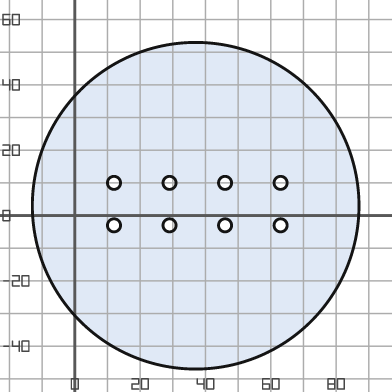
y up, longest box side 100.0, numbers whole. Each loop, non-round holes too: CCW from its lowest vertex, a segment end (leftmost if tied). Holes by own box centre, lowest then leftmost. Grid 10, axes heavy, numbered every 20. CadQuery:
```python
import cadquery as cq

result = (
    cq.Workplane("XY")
    .moveTo(37.0, 3.0)
    .circle(50.0)
    .moveTo(12.0, -3.0)
    .circle(2.0)
    .moveTo(29.0, -3.0)
    .circle(2.0)
    .moveTo(46.0, -3.0)
    .circle(2.0)
    .moveTo(63.0, -3.0)
    .circle(2.0)
    .moveTo(12.0, 10.0)
    .circle(2.0)
    .moveTo(29.0, 10.0)
    .circle(2.0)
    .moveTo(46.0, 10.0)
    .circle(2.0)
    .moveTo(63.0, 10.0)
    .circle(2.0)
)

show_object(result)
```